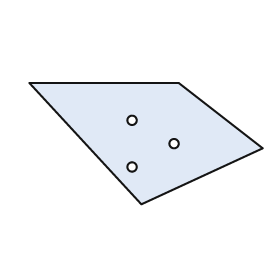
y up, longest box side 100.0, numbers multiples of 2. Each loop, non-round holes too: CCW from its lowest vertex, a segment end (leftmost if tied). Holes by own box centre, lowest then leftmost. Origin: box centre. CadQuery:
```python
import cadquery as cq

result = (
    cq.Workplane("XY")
    .moveTo(-2.0, -26.0)
    .lineTo(50.0, -2.0)
    .lineTo(14.0, 26.0)
    .lineTo(-50.0, 26.0)
    .close()
    .moveTo(-6.0, -10.0)
    .circle(2.0)
    .moveTo(12.0, 0.0)
    .circle(2.0)
    .moveTo(-6.0, 10.0)
    .circle(2.0)
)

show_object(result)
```